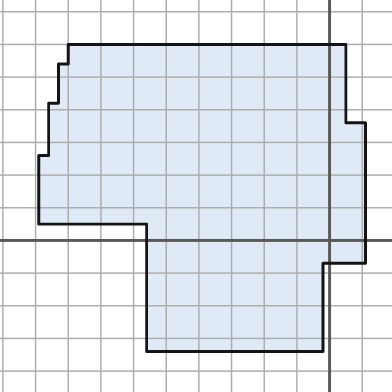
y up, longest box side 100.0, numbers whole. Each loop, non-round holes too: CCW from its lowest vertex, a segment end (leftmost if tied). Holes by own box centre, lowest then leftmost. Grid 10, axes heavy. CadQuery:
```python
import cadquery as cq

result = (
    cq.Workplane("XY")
    .moveTo(-56.0, -34.0)
    .lineTo(-2.0, -34.0)
    .lineTo(-2.0, -7.0)
    .lineTo(11.0, -7.0)
    .lineTo(11.0, 36.0)
    .lineTo(5.0, 36.0)
    .lineTo(5.0, 60.0)
    .lineTo(-80.0, 60.0)
    .lineTo(-80.0, 54.0)
    .lineTo(-83.0, 54.0)
    .lineTo(-83.0, 42.0)
    .lineTo(-86.0, 42.0)
    .lineTo(-86.0, 26.0)
    .lineTo(-89.0, 26.0)
    .lineTo(-89.0, 5.0)
    .lineTo(-56.0, 5.0)
    .close()
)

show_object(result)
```